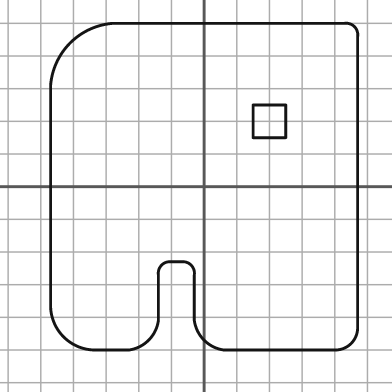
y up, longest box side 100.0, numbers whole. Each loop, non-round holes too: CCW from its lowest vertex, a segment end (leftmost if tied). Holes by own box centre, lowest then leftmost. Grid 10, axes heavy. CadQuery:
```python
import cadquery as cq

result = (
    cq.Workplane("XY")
    .moveTo(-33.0, -50.0)
    .lineTo(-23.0, -50.0)
    .threePointArc((-17.0, -47.0), (-14.0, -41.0))
    .lineTo(-14.0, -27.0)
    .threePointArc((-13.0, -24.0), (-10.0, -23.0))
    .lineTo(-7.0, -23.0)
    .threePointArc((-4.0, -24.0), (-3.0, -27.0))
    .lineTo(-3.0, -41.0)
    .threePointArc((0.0, -47.0), (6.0, -50.0))
    .lineTo(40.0, -50.0)
    .threePointArc((45.0, -48.0), (47.0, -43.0))
    .lineTo(47.0, 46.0)
    .threePointArc((46.0, 49.0), (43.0, 50.0))
    .lineTo(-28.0, 50.0)
    .threePointArc((-41.0, 44.0), (-47.0, 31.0))
    .lineTo(-47.0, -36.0)
    .threePointArc((-43.0, -46.0), (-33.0, -50.0))
    .close()
    .moveTo(15.0, 15.0)
    .lineTo(25.0, 15.0)
    .lineTo(25.0, 25.0)
    .lineTo(15.0, 25.0)
    .close()
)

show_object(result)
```